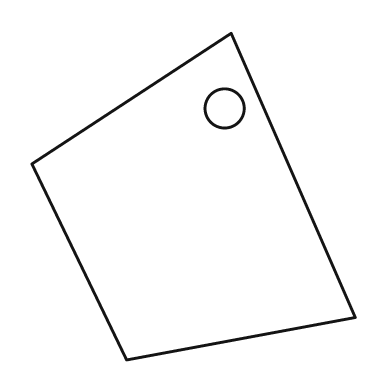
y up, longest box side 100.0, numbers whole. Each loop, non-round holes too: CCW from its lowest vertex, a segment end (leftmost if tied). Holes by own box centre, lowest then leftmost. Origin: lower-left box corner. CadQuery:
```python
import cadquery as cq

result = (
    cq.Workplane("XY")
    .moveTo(29.0, 0.0)
    .lineTo(99.0, 13.0)
    .lineTo(61.0, 100.0)
    .lineTo(0.0, 60.0)
    .close()
    .moveTo(59.0, 77.0)
    .circle(6.0)
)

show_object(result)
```